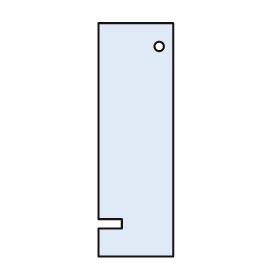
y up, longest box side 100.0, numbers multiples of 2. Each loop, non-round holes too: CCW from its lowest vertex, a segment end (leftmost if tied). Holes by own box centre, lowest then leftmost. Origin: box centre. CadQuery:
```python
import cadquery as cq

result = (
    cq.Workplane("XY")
    .moveTo(-16.0, -50.0)
    .lineTo(16.0, -50.0)
    .lineTo(16.0, 50.0)
    .lineTo(-16.0, 50.0)
    .lineTo(-16.0, -34.0)
    .lineTo(-6.0, -34.0)
    .lineTo(-6.0, -38.0)
    .lineTo(-16.0, -38.0)
    .close()
    .moveTo(10.0, 40.0)
    .circle(2.0)
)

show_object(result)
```